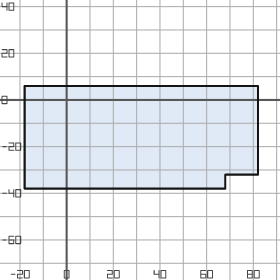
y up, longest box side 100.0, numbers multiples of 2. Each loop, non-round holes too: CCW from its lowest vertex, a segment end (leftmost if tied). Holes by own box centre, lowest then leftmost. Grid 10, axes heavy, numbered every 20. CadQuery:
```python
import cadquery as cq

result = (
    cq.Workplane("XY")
    .moveTo(-18.0, -38.0)
    .lineTo(68.0, -38.0)
    .lineTo(68.0, -32.0)
    .lineTo(82.0, -32.0)
    .lineTo(82.0, 6.0)
    .lineTo(-18.0, 6.0)
    .close()
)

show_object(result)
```